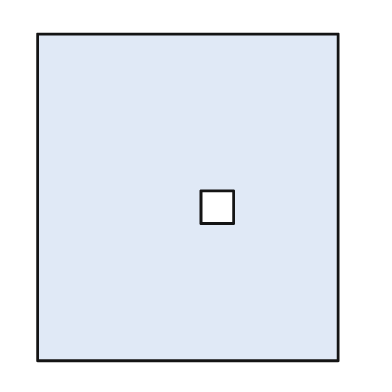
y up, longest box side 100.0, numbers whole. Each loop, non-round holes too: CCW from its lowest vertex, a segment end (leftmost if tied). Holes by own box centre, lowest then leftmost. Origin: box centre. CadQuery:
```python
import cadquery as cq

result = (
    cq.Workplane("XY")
    .moveTo(-46.0, -50.0)
    .lineTo(46.0, -50.0)
    .lineTo(46.0, 50.0)
    .lineTo(-46.0, 50.0)
    .close()
    .moveTo(4.0, -8.0)
    .lineTo(14.0, -8.0)
    .lineTo(14.0, 2.0)
    .lineTo(4.0, 2.0)
    .close()
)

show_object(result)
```